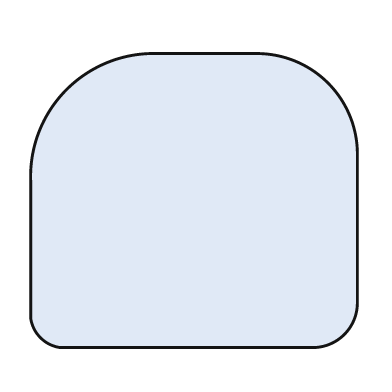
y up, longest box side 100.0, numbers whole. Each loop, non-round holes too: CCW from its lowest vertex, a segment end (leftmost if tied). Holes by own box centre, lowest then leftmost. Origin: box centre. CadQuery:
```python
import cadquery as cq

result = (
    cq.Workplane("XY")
    .moveTo(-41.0, -45.0)
    .lineTo(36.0, -45.0)
    .threePointArc((46.0, -41.0), (50.0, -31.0))
    .lineTo(50.0, 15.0)
    .threePointArc((41.0, 36.0), (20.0, 45.0))
    .lineTo(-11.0, 45.0)
    .threePointArc((-39.0, 34.0), (-50.0, 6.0))
    .lineTo(-50.0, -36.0)
    .threePointArc((-47.0, -42.0), (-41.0, -45.0))
    .close()
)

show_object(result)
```